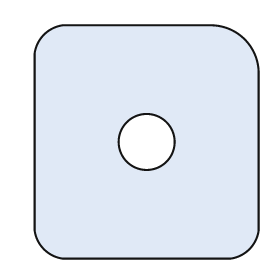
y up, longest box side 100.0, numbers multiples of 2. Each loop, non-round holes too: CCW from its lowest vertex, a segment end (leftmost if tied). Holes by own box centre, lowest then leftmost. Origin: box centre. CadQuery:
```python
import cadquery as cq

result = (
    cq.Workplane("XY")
    .moveTo(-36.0, -50.0)
    .lineTo(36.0, -50.0)
    .threePointArc((44.0, -46.0), (48.0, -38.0))
    .lineTo(48.0, 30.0)
    .threePointArc((42.0, 44.0), (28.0, 50.0))
    .lineTo(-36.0, 50.0)
    .threePointArc((-44.0, 46.0), (-48.0, 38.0))
    .lineTo(-48.0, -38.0)
    .threePointArc((-44.0, -46.0), (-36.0, -50.0))
    .close()
    .moveTo(0.0, 0.0)
    .circle(12.0)
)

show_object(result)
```